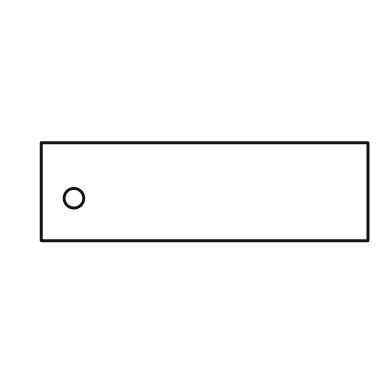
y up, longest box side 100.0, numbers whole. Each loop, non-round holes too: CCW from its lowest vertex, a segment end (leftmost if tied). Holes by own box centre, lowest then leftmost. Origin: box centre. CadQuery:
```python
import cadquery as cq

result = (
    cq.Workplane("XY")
    .moveTo(-50.0, -15.0)
    .lineTo(50.0, -15.0)
    .lineTo(50.0, 15.0)
    .lineTo(-50.0, 15.0)
    .close()
    .moveTo(-40.0, -2.0)
    .circle(3.0)
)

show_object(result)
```